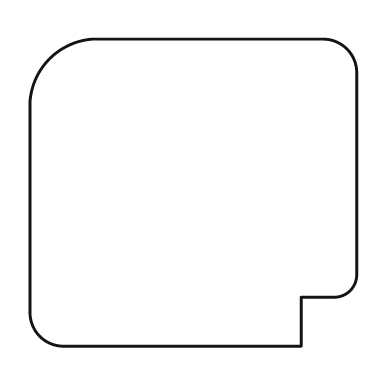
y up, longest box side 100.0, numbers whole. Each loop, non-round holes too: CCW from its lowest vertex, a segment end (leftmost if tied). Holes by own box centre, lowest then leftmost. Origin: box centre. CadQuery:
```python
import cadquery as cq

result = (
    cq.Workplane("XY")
    .moveTo(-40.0, -47.0)
    .lineTo(33.0, -47.0)
    .lineTo(33.0, -32.0)
    .lineTo(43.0, -32.0)
    .threePointArc((48.0, -30.0), (50.0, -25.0))
    .lineTo(50.0, 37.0)
    .threePointArc((47.0, 44.0), (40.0, 47.0))
    .lineTo(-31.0, 47.0)
    .threePointArc((-44.0, 41.0), (-50.0, 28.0))
    .lineTo(-50.0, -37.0)
    .threePointArc((-47.0, -44.0), (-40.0, -47.0))
    .close()
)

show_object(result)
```